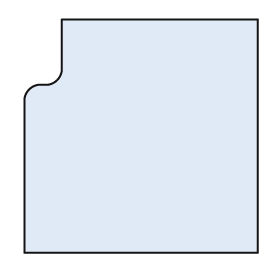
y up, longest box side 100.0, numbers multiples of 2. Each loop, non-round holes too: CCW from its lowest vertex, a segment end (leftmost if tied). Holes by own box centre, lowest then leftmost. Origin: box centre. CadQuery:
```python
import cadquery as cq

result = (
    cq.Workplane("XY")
    .moveTo(-50.0, -50.0)
    .lineTo(50.0, -50.0)
    .lineTo(50.0, 50.0)
    .lineTo(-34.0, 50.0)
    .lineTo(-34.0, 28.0)
    .threePointArc((-36.0, 24.0), (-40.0, 22.0))
    .lineTo(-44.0, 22.0)
    .threePointArc((-48.0, 20.0), (-50.0, 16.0))
    .close()
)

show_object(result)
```